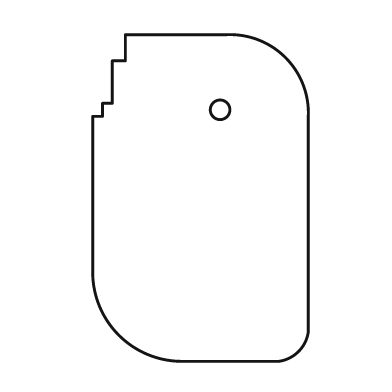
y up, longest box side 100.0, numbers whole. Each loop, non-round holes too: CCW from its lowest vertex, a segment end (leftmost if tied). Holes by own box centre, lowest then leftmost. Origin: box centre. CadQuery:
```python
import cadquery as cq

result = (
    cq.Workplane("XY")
    .moveTo(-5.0, -50.0)
    .lineTo(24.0, -50.0)
    .threePointArc((30.0, -47.0), (33.0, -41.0))
    .lineTo(33.0, 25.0)
    .threePointArc((26.0, 43.0), (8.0, 50.0))
    .lineTo(-23.0, 50.0)
    .lineTo(-23.0, 42.0)
    .lineTo(-27.0, 42.0)
    .lineTo(-27.0, 29.0)
    .lineTo(-30.0, 29.0)
    .lineTo(-30.0, 25.0)
    .lineTo(-33.0, 25.0)
    .lineTo(-33.0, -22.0)
    .threePointArc((-25.0, -42.0), (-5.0, -50.0))
    .close()
    .moveTo(6.0, 27.0)
    .circle(3.0)
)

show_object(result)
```